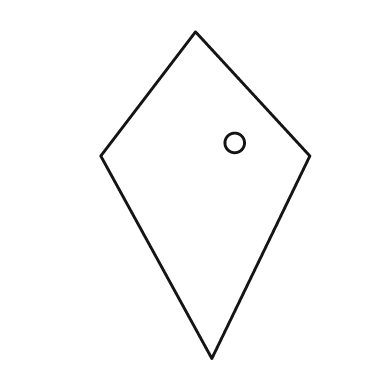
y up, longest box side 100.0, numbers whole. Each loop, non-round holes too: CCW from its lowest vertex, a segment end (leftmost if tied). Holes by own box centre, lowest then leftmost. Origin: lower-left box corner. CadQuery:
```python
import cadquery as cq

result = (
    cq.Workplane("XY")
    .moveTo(34.0, 0.0)
    .lineTo(64.0, 62.0)
    .lineTo(29.0, 100.0)
    .lineTo(0.0, 62.0)
    .close()
    .moveTo(41.0, 66.0)
    .circle(3.0)
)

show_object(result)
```